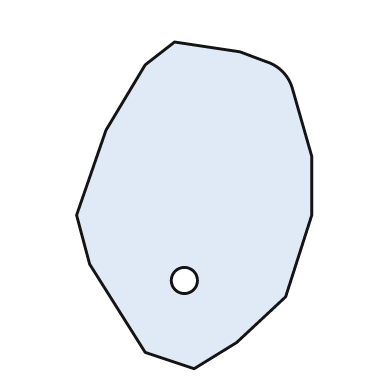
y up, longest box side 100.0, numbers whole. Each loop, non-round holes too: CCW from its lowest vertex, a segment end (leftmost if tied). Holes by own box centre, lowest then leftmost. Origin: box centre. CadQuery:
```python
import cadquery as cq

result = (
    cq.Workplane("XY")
    .moveTo(0.0, -50.0)
    .lineTo(13.0, -42.0)
    .lineTo(28.0, -28.0)
    .lineTo(36.0, -3.0)
    .lineTo(36.0, 15.0)
    .lineTo(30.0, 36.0)
    .threePointArc((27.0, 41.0), (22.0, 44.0))
    .lineTo(14.0, 47.0)
    .lineTo(-6.0, 50.0)
    .lineTo(-15.0, 43.0)
    .lineTo(-27.0, 23.0)
    .lineTo(-36.0, -3.0)
    .lineTo(-32.0, -18.0)
    .lineTo(-15.0, -45.0)
    .close()
    .moveTo(-3.0, -23.0)
    .circle(4.0)
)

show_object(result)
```